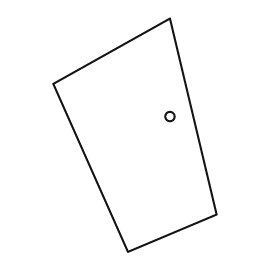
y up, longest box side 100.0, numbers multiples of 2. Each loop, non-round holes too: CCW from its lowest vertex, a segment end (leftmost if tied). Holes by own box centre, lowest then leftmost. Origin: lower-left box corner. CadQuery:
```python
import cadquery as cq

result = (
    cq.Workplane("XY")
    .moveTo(32.0, 0.0)
    .lineTo(70.0, 16.0)
    .lineTo(50.0, 100.0)
    .lineTo(0.0, 72.0)
    .close()
    .moveTo(50.0, 58.0)
    .circle(2.0)
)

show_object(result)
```